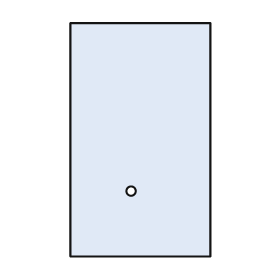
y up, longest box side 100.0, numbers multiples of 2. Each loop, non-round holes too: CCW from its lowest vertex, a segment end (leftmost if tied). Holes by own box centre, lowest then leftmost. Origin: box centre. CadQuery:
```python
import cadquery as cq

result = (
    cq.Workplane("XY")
    .moveTo(-30.0, -50.0)
    .lineTo(30.0, -50.0)
    .lineTo(30.0, 50.0)
    .lineTo(-30.0, 50.0)
    .close()
    .moveTo(-4.0, -22.0)
    .circle(2.0)
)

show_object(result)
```